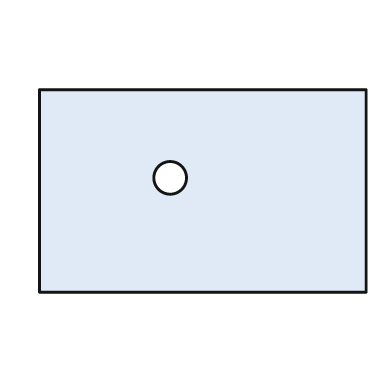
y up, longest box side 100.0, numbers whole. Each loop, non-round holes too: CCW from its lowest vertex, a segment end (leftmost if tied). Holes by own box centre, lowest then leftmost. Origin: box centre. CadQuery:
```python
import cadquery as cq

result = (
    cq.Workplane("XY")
    .moveTo(-50.0, -31.0)
    .lineTo(50.0, -31.0)
    .lineTo(50.0, 31.0)
    .lineTo(-50.0, 31.0)
    .close()
    .moveTo(-10.0, 4.0)
    .circle(5.0)
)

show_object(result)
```